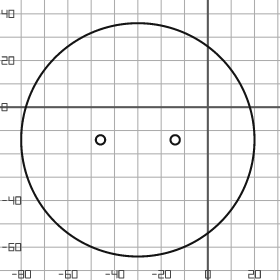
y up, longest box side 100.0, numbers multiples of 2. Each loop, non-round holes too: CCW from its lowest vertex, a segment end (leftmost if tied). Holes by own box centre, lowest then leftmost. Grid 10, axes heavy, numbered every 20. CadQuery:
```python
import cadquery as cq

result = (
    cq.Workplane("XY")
    .moveTo(-30.0, -14.0)
    .circle(50.0)
    .moveTo(-46.0, -14.0)
    .circle(2.0)
    .moveTo(-14.0, -14.0)
    .circle(2.0)
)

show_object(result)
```